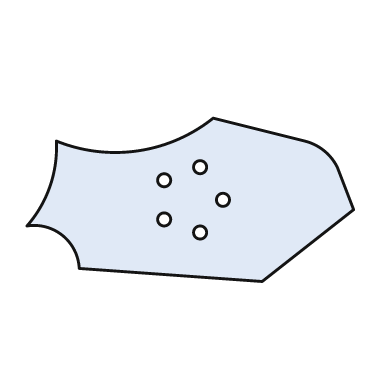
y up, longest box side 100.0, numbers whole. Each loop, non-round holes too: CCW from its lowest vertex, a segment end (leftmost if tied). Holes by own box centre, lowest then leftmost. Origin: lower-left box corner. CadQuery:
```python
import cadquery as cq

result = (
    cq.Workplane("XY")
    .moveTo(72.0, 0.0)
    .lineTo(100.0, 22.0)
    .lineTo(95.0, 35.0)
    .threePointArc((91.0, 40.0), (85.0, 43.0))
    .lineTo(57.0, 50.0)
    .threePointArc((34.0, 40.0), (9.0, 43.0))
    .threePointArc((7.0, 29.0), (0.0, 17.0))
    .threePointArc((11.0, 14.0), (16.0, 4.0))
    .close()
    .moveTo(53.0, 15.0)
    .circle(2.0)
    .moveTo(42.0, 19.0)
    .circle(2.0)
    .moveTo(60.0, 25.0)
    .circle(2.0)
    .moveTo(42.0, 31.0)
    .circle(2.0)
    .moveTo(53.0, 35.0)
    .circle(2.0)
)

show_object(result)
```